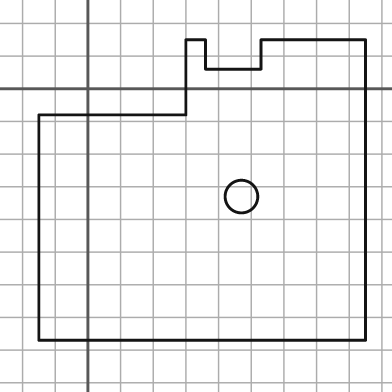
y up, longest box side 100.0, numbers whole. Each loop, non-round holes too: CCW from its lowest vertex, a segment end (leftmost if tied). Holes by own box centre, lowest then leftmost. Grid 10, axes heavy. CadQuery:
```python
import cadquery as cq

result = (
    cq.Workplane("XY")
    .moveTo(-15.0, -77.0)
    .lineTo(85.0, -77.0)
    .lineTo(85.0, 15.0)
    .lineTo(53.0, 15.0)
    .lineTo(53.0, 6.0)
    .lineTo(36.0, 6.0)
    .lineTo(36.0, 15.0)
    .lineTo(30.0, 15.0)
    .lineTo(30.0, -8.0)
    .lineTo(-15.0, -8.0)
    .close()
    .moveTo(47.0, -33.0)
    .circle(5.0)
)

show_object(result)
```